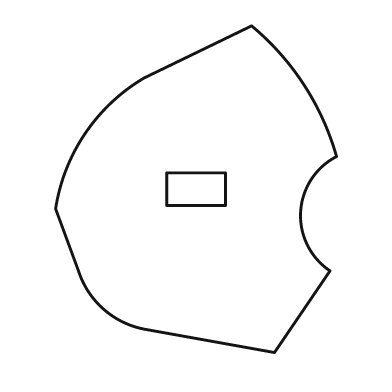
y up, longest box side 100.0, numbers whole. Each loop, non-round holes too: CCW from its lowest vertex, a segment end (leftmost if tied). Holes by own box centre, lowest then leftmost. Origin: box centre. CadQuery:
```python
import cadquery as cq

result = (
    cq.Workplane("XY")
    .moveTo(24.0, -50.0)
    .lineTo(41.0, -25.0)
    .threePointArc((32.0, -7.0), (43.0, 10.0))
    .threePointArc((33.0, 32.0), (17.0, 50.0))
    .lineTo(-16.0, 34.0)
    .threePointArc((-34.0, 17.0), (-43.0, -6.0))
    .lineTo(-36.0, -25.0)
    .threePointArc((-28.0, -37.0), (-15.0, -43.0))
    .close()
    .moveTo(-9.0, -5.0)
    .lineTo(9.0, -5.0)
    .lineTo(9.0, 5.0)
    .lineTo(-9.0, 5.0)
    .close()
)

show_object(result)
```